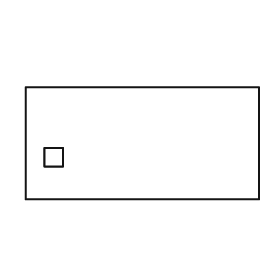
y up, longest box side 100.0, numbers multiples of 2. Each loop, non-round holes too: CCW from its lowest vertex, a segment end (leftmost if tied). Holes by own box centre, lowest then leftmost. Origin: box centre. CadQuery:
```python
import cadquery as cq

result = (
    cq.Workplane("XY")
    .moveTo(-50.0, -24.0)
    .lineTo(50.0, -24.0)
    .lineTo(50.0, 24.0)
    .lineTo(-50.0, 24.0)
    .close()
    .moveTo(-42.0, -10.0)
    .lineTo(-34.0, -10.0)
    .lineTo(-34.0, -2.0)
    .lineTo(-42.0, -2.0)
    .close()
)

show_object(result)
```